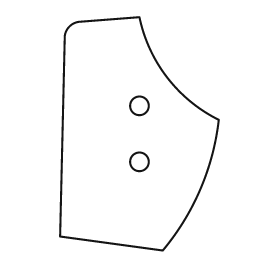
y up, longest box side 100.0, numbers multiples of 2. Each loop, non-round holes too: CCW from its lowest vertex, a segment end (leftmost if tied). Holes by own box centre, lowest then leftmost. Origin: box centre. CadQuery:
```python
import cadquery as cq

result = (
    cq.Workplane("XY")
    .moveTo(10.0, -50.0)
    .threePointArc((26.0, -24.0), (34.0, 6.0))
    .threePointArc((12.0, 24.0), (0.0, 50.0))
    .lineTo(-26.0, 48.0)
    .threePointArc((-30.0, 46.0), (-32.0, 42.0))
    .lineTo(-34.0, -44.0)
    .close()
    .moveTo(0.0, -12.0)
    .circle(4.0)
    .moveTo(0.0, 12.0)
    .circle(4.0)
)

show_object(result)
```